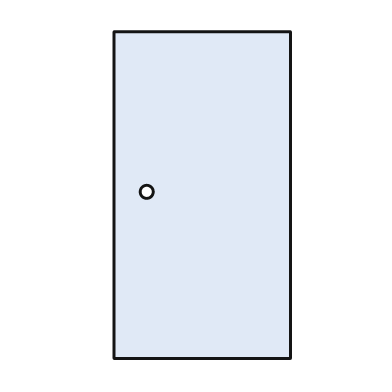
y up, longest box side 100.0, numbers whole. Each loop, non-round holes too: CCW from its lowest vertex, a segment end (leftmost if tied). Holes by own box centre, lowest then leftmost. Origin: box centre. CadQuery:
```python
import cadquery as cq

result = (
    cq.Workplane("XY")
    .moveTo(-27.0, -50.0)
    .lineTo(27.0, -50.0)
    .lineTo(27.0, 50.0)
    .lineTo(-27.0, 50.0)
    .close()
    .moveTo(-17.0, 1.0)
    .circle(2.0)
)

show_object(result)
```